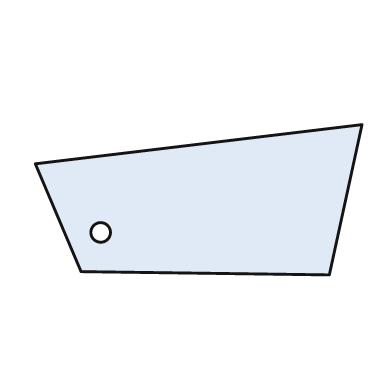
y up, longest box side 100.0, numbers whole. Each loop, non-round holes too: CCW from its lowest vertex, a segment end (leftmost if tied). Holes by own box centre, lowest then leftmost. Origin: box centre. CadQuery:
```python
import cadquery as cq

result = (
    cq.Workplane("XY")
    .moveTo(40.0, -23.0)
    .lineTo(50.0, 23.0)
    .lineTo(-50.0, 11.0)
    .lineTo(-36.0, -22.0)
    .close()
    .moveTo(-30.0, -10.0)
    .circle(3.0)
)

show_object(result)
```